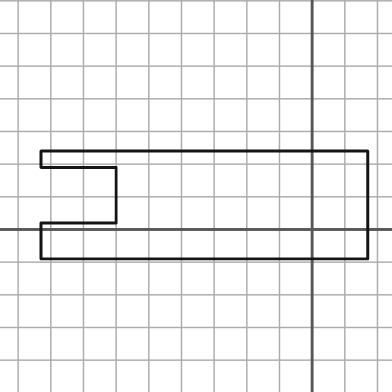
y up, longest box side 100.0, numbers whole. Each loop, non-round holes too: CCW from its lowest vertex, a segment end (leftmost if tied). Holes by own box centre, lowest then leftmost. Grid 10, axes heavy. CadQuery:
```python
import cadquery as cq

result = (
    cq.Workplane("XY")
    .moveTo(-83.0, -9.0)
    .lineTo(17.0, -9.0)
    .lineTo(17.0, 24.0)
    .lineTo(-83.0, 24.0)
    .lineTo(-83.0, 19.0)
    .lineTo(-60.0, 19.0)
    .lineTo(-60.0, 2.0)
    .lineTo(-83.0, 2.0)
    .close()
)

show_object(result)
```